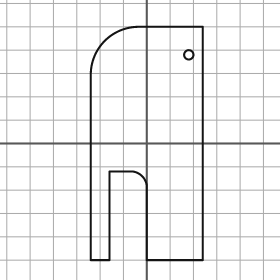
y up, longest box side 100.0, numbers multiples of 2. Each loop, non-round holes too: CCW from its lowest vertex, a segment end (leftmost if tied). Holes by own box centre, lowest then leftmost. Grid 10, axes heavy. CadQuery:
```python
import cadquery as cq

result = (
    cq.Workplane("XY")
    .moveTo(-24.0, -50.0)
    .lineTo(-16.0, -50.0)
    .lineTo(-16.0, -12.0)
    .lineTo(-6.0, -12.0)
    .threePointArc((-2.0, -14.0), (0.0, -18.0))
    .lineTo(0.0, -50.0)
    .lineTo(24.0, -50.0)
    .lineTo(24.0, 50.0)
    .lineTo(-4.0, 50.0)
    .threePointArc((-18.0, 44.0), (-24.0, 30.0))
    .close()
    .moveTo(18.0, 38.0)
    .circle(2.0)
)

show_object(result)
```